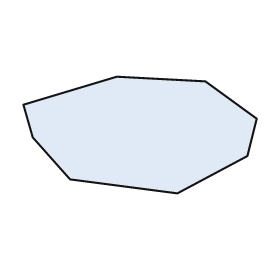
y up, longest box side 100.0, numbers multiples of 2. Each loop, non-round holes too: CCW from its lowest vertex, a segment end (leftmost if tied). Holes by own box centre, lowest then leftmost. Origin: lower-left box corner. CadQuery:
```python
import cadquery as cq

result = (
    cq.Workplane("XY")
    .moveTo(66.0, 0.0)
    .lineTo(96.0, 16.0)
    .lineTo(100.0, 32.0)
    .lineTo(78.0, 48.0)
    .lineTo(40.0, 50.0)
    .lineTo(0.0, 38.0)
    .lineTo(4.0, 24.0)
    .lineTo(20.0, 6.0)
    .close()
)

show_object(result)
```